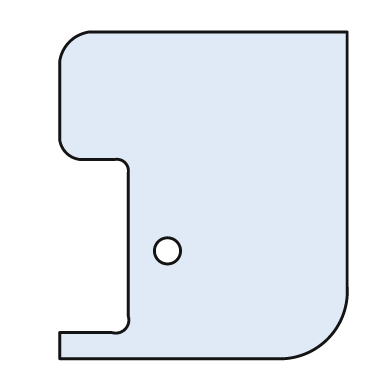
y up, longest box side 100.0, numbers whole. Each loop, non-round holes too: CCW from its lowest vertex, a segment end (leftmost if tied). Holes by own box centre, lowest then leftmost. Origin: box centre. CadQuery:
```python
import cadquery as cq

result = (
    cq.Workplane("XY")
    .moveTo(-44.0, -50.0)
    .lineTo(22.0, -50.0)
    .threePointArc((38.0, -44.0), (44.0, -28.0))
    .lineTo(44.0, 50.0)
    .lineTo(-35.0, 50.0)
    .threePointArc((-41.0, 47.0), (-44.0, 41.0))
    .lineTo(-44.0, 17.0)
    .threePointArc((-42.0, 13.0), (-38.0, 11.0))
    .lineTo(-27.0, 11.0)
    .threePointArc((-24.0, 10.0), (-23.0, 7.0))
    .lineTo(-23.0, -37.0)
    .threePointArc((-24.0, -41.0), (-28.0, -42.0))
    .lineTo(-44.0, -42.0)
    .close()
    .moveTo(-11.0, -17.0)
    .circle(4.0)
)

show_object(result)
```